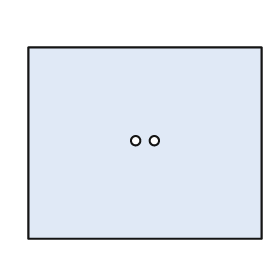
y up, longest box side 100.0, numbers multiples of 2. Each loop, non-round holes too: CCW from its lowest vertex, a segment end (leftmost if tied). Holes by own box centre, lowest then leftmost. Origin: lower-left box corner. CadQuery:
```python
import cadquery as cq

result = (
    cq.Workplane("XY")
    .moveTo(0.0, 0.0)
    .lineTo(100.0, 0.0)
    .lineTo(100.0, 82.0)
    .lineTo(0.0, 82.0)
    .close()
    .moveTo(46.0, 42.0)
    .circle(2.0)
    .moveTo(54.0, 42.0)
    .circle(2.0)
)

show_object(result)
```